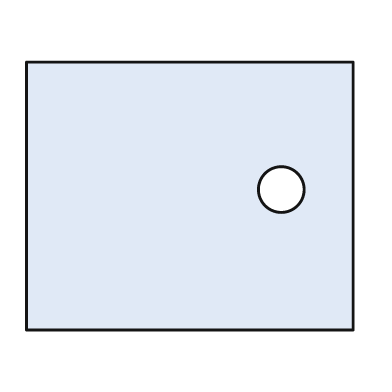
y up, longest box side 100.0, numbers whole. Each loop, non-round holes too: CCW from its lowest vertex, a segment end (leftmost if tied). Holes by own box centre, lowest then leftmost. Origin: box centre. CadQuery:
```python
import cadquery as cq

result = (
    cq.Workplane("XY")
    .moveTo(-50.0, -41.0)
    .lineTo(50.0, -41.0)
    .lineTo(50.0, 41.0)
    .lineTo(-50.0, 41.0)
    .close()
    .moveTo(28.0, 2.0)
    .circle(7.0)
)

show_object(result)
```